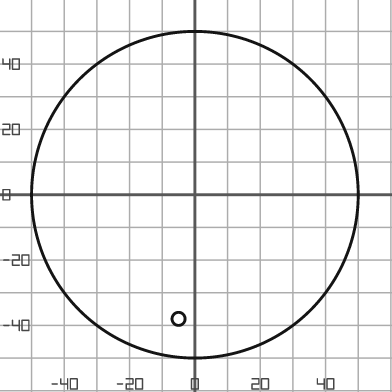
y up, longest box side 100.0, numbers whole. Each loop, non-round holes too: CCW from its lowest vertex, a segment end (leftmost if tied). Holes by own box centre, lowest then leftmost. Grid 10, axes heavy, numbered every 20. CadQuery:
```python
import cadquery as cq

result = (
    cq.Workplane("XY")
    .moveTo(0.0, 0.0)
    .circle(50.0)
    .moveTo(-5.0, -38.0)
    .circle(2.0)
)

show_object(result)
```